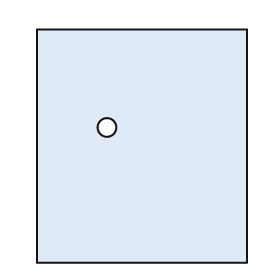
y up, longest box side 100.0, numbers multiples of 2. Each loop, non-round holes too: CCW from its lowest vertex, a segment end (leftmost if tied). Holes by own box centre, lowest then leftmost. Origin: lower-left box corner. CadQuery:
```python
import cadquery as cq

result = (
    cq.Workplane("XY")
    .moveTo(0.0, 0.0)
    .lineTo(90.0, 0.0)
    .lineTo(90.0, 100.0)
    .lineTo(0.0, 100.0)
    .close()
    .moveTo(30.0, 58.0)
    .circle(4.0)
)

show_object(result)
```